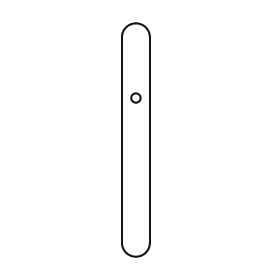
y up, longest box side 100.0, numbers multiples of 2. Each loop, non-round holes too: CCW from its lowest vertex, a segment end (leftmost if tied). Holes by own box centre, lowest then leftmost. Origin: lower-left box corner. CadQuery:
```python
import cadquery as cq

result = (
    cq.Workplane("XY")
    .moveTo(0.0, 6.0)
    .threePointArc((6.0, 0.0), (12.0, 6.0))
    .lineTo(12.0, 94.0)
    .threePointArc((6.0, 100.0), (0.0, 94.0))
    .close()
    .moveTo(6.0, 68.0)
    .circle(2.0)
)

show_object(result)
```